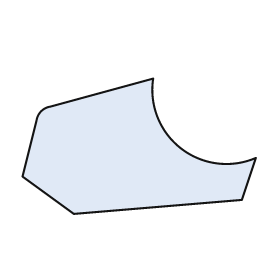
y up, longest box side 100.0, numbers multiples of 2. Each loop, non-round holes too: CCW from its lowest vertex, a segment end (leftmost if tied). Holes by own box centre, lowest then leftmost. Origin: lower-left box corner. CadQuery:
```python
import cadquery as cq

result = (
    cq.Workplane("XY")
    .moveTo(22.0, 0.0)
    .lineTo(94.0, 6.0)
    .lineTo(100.0, 24.0)
    .threePointArc((68.0, 28.0), (56.0, 58.0))
    .lineTo(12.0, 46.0)
    .threePointArc((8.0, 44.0), (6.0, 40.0))
    .lineTo(0.0, 16.0)
    .close()
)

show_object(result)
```